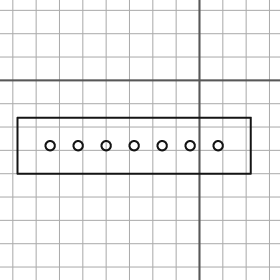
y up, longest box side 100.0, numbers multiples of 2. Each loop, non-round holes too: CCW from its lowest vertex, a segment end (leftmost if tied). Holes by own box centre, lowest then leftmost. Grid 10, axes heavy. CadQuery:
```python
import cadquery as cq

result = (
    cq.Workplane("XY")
    .moveTo(-78.0, -40.0)
    .lineTo(22.0, -40.0)
    .lineTo(22.0, -16.0)
    .lineTo(-78.0, -16.0)
    .close()
    .moveTo(-64.0, -28.0)
    .circle(2.0)
    .moveTo(-52.0, -28.0)
    .circle(2.0)
    .moveTo(-40.0, -28.0)
    .circle(2.0)
    .moveTo(-28.0, -28.0)
    .circle(2.0)
    .moveTo(-16.0, -28.0)
    .circle(2.0)
    .moveTo(-4.0, -28.0)
    .circle(2.0)
    .moveTo(8.0, -28.0)
    .circle(2.0)
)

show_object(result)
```